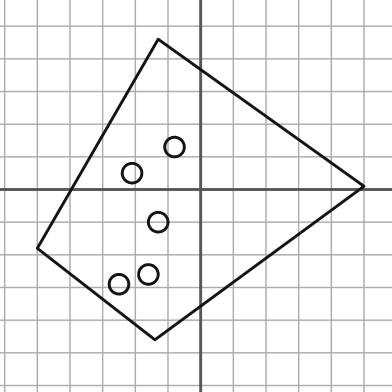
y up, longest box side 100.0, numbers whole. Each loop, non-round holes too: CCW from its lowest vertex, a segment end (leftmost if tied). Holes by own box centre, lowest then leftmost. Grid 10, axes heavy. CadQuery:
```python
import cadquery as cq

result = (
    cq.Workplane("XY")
    .moveTo(-14.0, -46.0)
    .lineTo(50.0, 1.0)
    .lineTo(-13.0, 46.0)
    .lineTo(-50.0, -18.0)
    .close()
    .moveTo(-25.0, -29.0)
    .circle(3.0)
    .moveTo(-16.0, -26.0)
    .circle(3.0)
    .moveTo(-13.0, -10.0)
    .circle(3.0)
    .moveTo(-21.0, 5.0)
    .circle(3.0)
    .moveTo(-8.0, 13.0)
    .circle(3.0)
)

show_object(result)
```